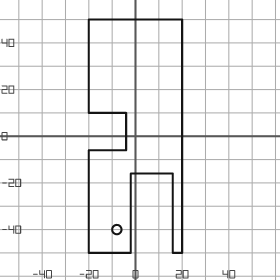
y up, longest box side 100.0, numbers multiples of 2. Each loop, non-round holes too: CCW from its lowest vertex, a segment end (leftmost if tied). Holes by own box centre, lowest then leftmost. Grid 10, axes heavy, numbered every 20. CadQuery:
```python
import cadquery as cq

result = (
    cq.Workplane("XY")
    .moveTo(-20.0, -50.0)
    .lineTo(-2.0, -50.0)
    .lineTo(-2.0, -16.0)
    .lineTo(16.0, -16.0)
    .lineTo(16.0, -50.0)
    .lineTo(20.0, -50.0)
    .lineTo(20.0, 50.0)
    .lineTo(-20.0, 50.0)
    .lineTo(-20.0, 10.0)
    .lineTo(-4.0, 10.0)
    .lineTo(-4.0, -6.0)
    .lineTo(-20.0, -6.0)
    .close()
    .moveTo(-8.0, -40.0)
    .circle(2.0)
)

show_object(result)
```